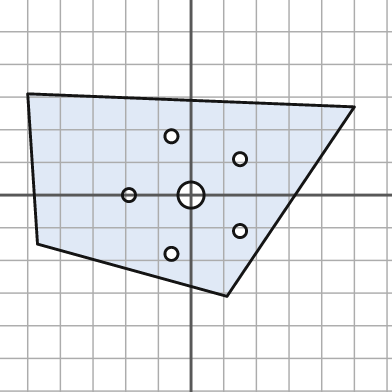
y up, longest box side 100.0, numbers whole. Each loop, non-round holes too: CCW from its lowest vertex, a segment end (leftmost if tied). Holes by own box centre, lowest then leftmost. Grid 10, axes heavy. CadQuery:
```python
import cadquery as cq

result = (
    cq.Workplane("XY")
    .moveTo(11.0, -31.0)
    .lineTo(50.0, 27.0)
    .lineTo(-50.0, 31.0)
    .lineTo(-47.0, -15.0)
    .close()
    .moveTo(-6.0, -18.0)
    .circle(2.0)
    .moveTo(15.0, -11.0)
    .circle(2.0)
    .moveTo(-19.0, 0.0)
    .circle(2.0)
    .moveTo(0.0, 0.0)
    .circle(4.0)
    .moveTo(15.0, 11.0)
    .circle(2.0)
    .moveTo(-6.0, 18.0)
    .circle(2.0)
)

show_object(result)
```